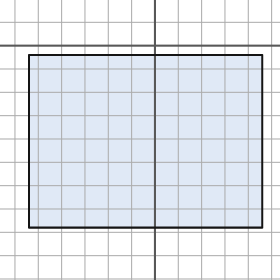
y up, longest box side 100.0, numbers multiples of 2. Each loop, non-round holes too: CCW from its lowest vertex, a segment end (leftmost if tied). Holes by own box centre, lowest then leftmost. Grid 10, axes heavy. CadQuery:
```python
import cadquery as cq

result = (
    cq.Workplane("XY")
    .moveTo(-54.0, -78.0)
    .lineTo(46.0, -78.0)
    .lineTo(46.0, -4.0)
    .lineTo(-54.0, -4.0)
    .close()
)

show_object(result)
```